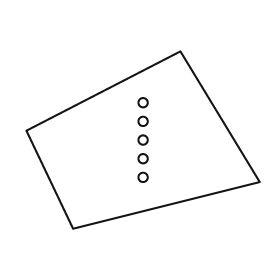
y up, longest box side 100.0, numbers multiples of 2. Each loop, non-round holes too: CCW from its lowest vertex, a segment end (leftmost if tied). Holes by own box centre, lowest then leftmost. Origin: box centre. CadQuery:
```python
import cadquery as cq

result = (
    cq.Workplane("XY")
    .moveTo(-30.0, -38.0)
    .lineTo(50.0, -18.0)
    .lineTo(16.0, 38.0)
    .lineTo(-50.0, 4.0)
    .close()
    .moveTo(0.0, -16.0)
    .circle(2.0)
    .moveTo(0.0, -8.0)
    .circle(2.0)
    .moveTo(0.0, 0.0)
    .circle(2.0)
    .moveTo(0.0, 8.0)
    .circle(2.0)
    .moveTo(0.0, 16.0)
    .circle(2.0)
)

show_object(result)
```